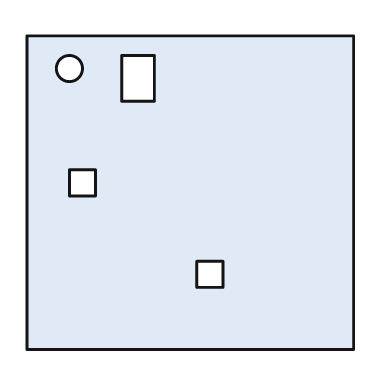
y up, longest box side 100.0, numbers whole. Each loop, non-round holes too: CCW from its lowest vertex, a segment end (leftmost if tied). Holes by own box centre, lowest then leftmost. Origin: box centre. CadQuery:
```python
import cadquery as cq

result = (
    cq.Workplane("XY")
    .moveTo(-50.0, -48.0)
    .lineTo(50.0, -48.0)
    .lineTo(50.0, 48.0)
    .lineTo(-50.0, 48.0)
    .close()
    .moveTo(2.0, -29.0)
    .lineTo(10.0, -29.0)
    .lineTo(10.0, -21.0)
    .lineTo(2.0, -21.0)
    .close()
    .moveTo(-37.0, -1.0)
    .lineTo(-29.0, -1.0)
    .lineTo(-29.0, 7.0)
    .lineTo(-37.0, 7.0)
    .close()
    .moveTo(-21.0, 28.0)
    .lineTo(-11.0, 28.0)
    .lineTo(-11.0, 42.0)
    .lineTo(-21.0, 42.0)
    .close()
    .moveTo(-37.0, 38.0)
    .circle(4.0)
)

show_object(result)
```